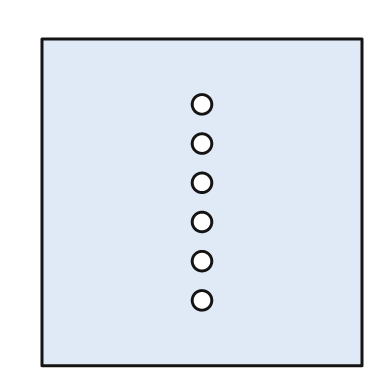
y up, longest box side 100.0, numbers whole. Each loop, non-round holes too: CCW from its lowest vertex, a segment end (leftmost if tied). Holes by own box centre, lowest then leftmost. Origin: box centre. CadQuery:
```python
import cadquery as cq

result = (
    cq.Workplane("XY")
    .moveTo(-49.0, -50.0)
    .lineTo(49.0, -50.0)
    .lineTo(49.0, 50.0)
    .lineTo(-49.0, 50.0)
    .close()
    .moveTo(0.0, -30.0)
    .circle(3.0)
    .moveTo(0.0, -18.0)
    .circle(3.0)
    .moveTo(0.0, -6.0)
    .circle(3.0)
    .moveTo(0.0, 6.0)
    .circle(3.0)
    .moveTo(0.0, 18.0)
    .circle(3.0)
    .moveTo(0.0, 30.0)
    .circle(3.0)
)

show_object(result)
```